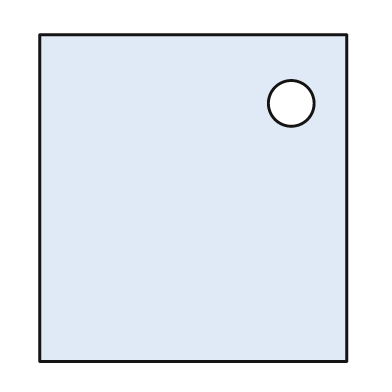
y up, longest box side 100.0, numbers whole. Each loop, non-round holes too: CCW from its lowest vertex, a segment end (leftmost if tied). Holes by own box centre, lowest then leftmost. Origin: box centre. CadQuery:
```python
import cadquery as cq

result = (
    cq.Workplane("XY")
    .moveTo(-47.0, -50.0)
    .lineTo(47.0, -50.0)
    .lineTo(47.0, 50.0)
    .lineTo(-47.0, 50.0)
    .close()
    .moveTo(30.0, 29.0)
    .circle(7.0)
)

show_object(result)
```